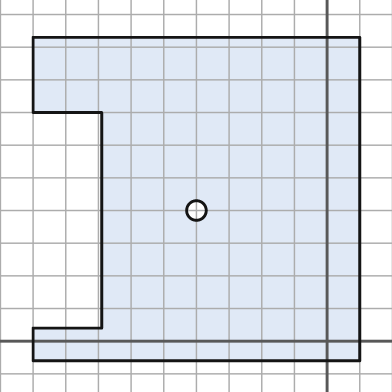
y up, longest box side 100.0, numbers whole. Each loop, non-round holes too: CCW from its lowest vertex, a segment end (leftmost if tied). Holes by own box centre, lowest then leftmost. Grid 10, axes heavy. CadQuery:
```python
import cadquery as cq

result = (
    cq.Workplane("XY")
    .moveTo(-90.0, -6.0)
    .lineTo(10.0, -6.0)
    .lineTo(10.0, 93.0)
    .lineTo(-90.0, 93.0)
    .lineTo(-90.0, 70.0)
    .lineTo(-69.0, 70.0)
    .lineTo(-69.0, 4.0)
    .lineTo(-90.0, 4.0)
    .close()
    .moveTo(-40.0, 40.0)
    .circle(3.0)
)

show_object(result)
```